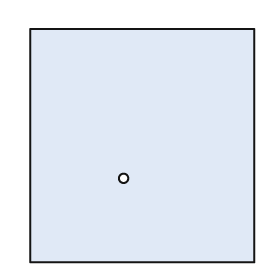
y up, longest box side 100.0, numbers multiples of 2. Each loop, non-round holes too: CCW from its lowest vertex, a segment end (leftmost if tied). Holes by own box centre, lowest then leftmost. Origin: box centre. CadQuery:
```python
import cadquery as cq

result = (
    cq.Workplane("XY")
    .moveTo(-48.0, -50.0)
    .lineTo(48.0, -50.0)
    .lineTo(48.0, 50.0)
    .lineTo(-48.0, 50.0)
    .close()
    .moveTo(-8.0, -14.0)
    .circle(2.0)
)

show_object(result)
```